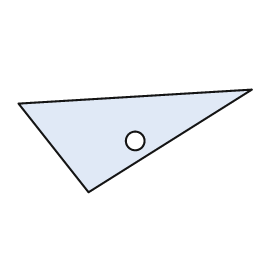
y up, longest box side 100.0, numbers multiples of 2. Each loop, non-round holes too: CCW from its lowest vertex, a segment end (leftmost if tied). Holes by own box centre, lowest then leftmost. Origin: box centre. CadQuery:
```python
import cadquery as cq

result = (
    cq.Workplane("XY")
    .moveTo(-20.0, -22.0)
    .lineTo(50.0, 22.0)
    .lineTo(-50.0, 16.0)
    .close()
    .moveTo(0.0, 0.0)
    .circle(4.0)
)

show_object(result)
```